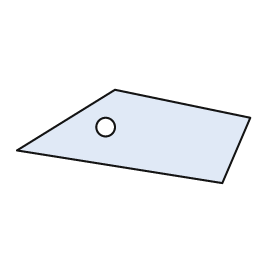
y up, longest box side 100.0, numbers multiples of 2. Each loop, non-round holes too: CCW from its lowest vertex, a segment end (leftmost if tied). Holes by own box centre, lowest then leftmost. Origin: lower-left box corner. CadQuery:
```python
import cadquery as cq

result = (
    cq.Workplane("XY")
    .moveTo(88.0, 0.0)
    .lineTo(100.0, 28.0)
    .lineTo(42.0, 40.0)
    .lineTo(0.0, 14.0)
    .close()
    .moveTo(38.0, 24.0)
    .circle(4.0)
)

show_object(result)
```